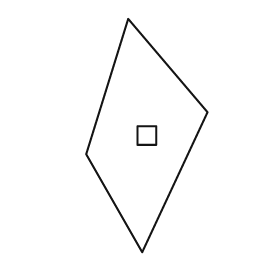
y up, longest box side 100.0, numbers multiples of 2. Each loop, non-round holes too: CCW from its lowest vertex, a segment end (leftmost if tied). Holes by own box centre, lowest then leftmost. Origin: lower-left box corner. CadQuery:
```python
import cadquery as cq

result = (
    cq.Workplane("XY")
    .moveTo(24.0, 0.0)
    .lineTo(52.0, 60.0)
    .lineTo(18.0, 100.0)
    .lineTo(0.0, 42.0)
    .close()
    .moveTo(22.0, 46.0)
    .lineTo(30.0, 46.0)
    .lineTo(30.0, 54.0)
    .lineTo(22.0, 54.0)
    .close()
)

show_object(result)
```